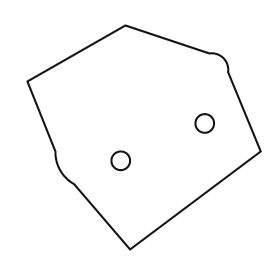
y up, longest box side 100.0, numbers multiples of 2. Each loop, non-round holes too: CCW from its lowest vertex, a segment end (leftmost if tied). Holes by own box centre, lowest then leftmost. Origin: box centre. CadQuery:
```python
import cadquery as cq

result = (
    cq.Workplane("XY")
    .moveTo(-6.0, -48.0)
    .lineTo(50.0, -6.0)
    .lineTo(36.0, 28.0)
    .threePointArc((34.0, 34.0), (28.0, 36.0))
    .lineTo(-8.0, 48.0)
    .lineTo(-50.0, 24.0)
    .lineTo(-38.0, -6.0)
    .threePointArc((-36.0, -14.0), (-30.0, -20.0))
    .close()
    .moveTo(-10.0, -10.0)
    .circle(4.0)
    .moveTo(26.0, 6.0)
    .circle(4.0)
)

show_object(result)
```